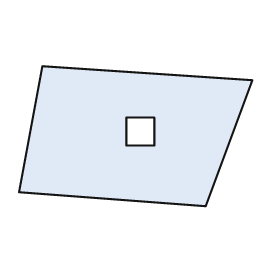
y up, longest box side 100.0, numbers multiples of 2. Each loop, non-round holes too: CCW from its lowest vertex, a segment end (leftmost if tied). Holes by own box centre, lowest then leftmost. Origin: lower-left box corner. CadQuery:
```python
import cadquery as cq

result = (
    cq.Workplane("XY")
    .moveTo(80.0, 0.0)
    .lineTo(100.0, 54.0)
    .lineTo(10.0, 60.0)
    .lineTo(0.0, 6.0)
    .close()
    .moveTo(46.0, 26.0)
    .lineTo(58.0, 26.0)
    .lineTo(58.0, 38.0)
    .lineTo(46.0, 38.0)
    .close()
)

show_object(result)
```